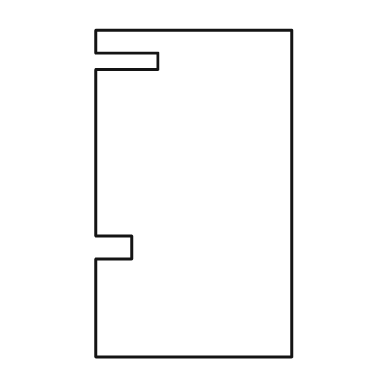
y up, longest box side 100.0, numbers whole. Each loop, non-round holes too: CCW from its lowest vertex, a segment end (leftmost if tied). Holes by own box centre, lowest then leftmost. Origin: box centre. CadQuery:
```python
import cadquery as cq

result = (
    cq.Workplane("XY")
    .moveTo(-30.0, -50.0)
    .lineTo(30.0, -50.0)
    .lineTo(30.0, 50.0)
    .lineTo(-30.0, 50.0)
    .lineTo(-30.0, 43.0)
    .lineTo(-11.0, 43.0)
    .lineTo(-11.0, 38.0)
    .lineTo(-30.0, 38.0)
    .lineTo(-30.0, -13.0)
    .lineTo(-19.0, -13.0)
    .lineTo(-19.0, -20.0)
    .lineTo(-30.0, -20.0)
    .close()
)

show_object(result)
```